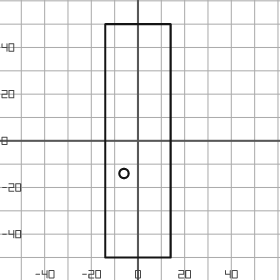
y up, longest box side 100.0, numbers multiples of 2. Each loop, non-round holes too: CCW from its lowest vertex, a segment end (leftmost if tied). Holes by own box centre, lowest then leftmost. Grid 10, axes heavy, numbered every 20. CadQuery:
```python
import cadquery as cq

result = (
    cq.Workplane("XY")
    .moveTo(-14.0, -50.0)
    .lineTo(14.0, -50.0)
    .lineTo(14.0, 50.0)
    .lineTo(-14.0, 50.0)
    .close()
    .moveTo(-6.0, -14.0)
    .circle(2.0)
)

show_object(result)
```